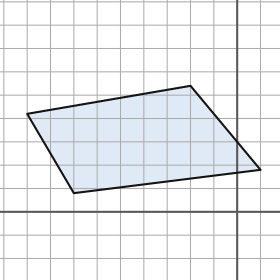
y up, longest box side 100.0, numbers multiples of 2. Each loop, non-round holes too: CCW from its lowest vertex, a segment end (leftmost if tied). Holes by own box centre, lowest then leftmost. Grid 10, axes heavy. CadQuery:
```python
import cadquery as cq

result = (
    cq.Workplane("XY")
    .moveTo(-70.0, 8.0)
    .lineTo(10.0, 18.0)
    .lineTo(-20.0, 54.0)
    .lineTo(-90.0, 42.0)
    .close()
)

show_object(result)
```